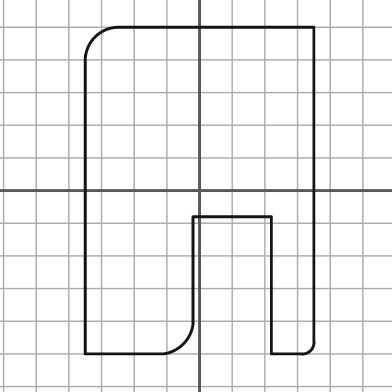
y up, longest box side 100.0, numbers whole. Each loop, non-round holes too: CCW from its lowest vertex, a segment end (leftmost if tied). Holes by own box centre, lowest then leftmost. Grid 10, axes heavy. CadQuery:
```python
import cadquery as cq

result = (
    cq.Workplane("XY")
    .moveTo(-35.0, -50.0)
    .lineTo(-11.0, -50.0)
    .threePointArc((-5.0, -47.0), (-2.0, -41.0))
    .lineTo(-2.0, -8.0)
    .lineTo(22.0, -8.0)
    .lineTo(22.0, -50.0)
    .lineTo(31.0, -50.0)
    .threePointArc((34.0, -49.0), (35.0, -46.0))
    .lineTo(35.0, 50.0)
    .lineTo(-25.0, 50.0)
    .threePointArc((-32.0, 47.0), (-35.0, 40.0))
    .close()
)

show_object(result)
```